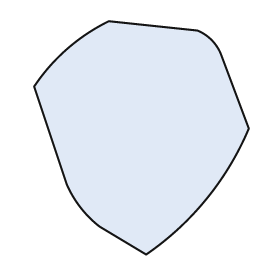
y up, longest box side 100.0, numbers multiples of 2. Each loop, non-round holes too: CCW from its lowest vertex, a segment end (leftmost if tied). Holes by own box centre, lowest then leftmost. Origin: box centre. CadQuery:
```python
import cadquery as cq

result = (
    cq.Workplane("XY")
    .moveTo(2.0, -50.0)
    .threePointArc((28.0, -26.0), (46.0, 4.0))
    .lineTo(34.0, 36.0)
    .threePointArc((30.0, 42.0), (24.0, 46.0))
    .lineTo(-14.0, 50.0)
    .threePointArc((-32.0, 38.0), (-46.0, 22.0))
    .lineTo(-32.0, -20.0)
    .threePointArc((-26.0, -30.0), (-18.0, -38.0))
    .close()
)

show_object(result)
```